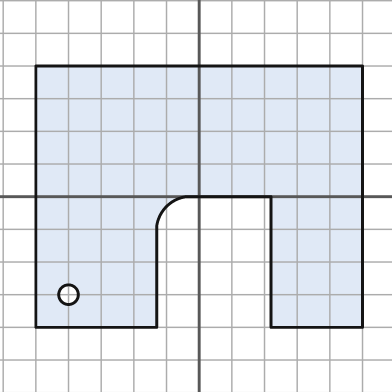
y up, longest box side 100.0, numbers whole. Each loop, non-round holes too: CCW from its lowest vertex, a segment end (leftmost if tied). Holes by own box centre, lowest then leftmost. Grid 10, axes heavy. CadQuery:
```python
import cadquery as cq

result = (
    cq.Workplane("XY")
    .moveTo(-50.0, -40.0)
    .lineTo(-13.0, -40.0)
    .lineTo(-13.0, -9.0)
    .threePointArc((-10.0, -3.0), (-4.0, 0.0))
    .lineTo(22.0, 0.0)
    .lineTo(22.0, -40.0)
    .lineTo(50.0, -40.0)
    .lineTo(50.0, 40.0)
    .lineTo(-50.0, 40.0)
    .close()
    .moveTo(-40.0, -30.0)
    .circle(3.0)
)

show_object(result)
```